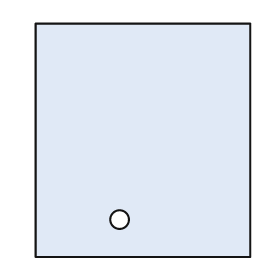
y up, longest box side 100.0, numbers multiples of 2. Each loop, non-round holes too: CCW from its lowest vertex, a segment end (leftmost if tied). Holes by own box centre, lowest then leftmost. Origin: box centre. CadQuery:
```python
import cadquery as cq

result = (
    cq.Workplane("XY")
    .moveTo(-46.0, -50.0)
    .lineTo(46.0, -50.0)
    .lineTo(46.0, 50.0)
    .lineTo(-46.0, 50.0)
    .close()
    .moveTo(-10.0, -34.0)
    .circle(4.0)
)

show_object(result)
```